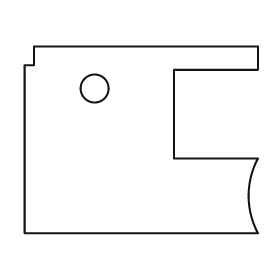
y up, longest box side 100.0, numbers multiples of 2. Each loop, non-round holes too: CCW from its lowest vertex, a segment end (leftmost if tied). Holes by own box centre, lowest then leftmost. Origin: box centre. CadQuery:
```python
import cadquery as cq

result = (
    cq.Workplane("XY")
    .moveTo(-50.0, -40.0)
    .lineTo(50.0, -40.0)
    .threePointArc((46.0, -24.0), (50.0, -8.0))
    .lineTo(14.0, -8.0)
    .lineTo(14.0, 30.0)
    .lineTo(50.0, 30.0)
    .lineTo(50.0, 40.0)
    .lineTo(-46.0, 40.0)
    .lineTo(-46.0, 32.0)
    .lineTo(-50.0, 32.0)
    .close()
    .moveTo(-20.0, 22.0)
    .circle(6.0)
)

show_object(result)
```